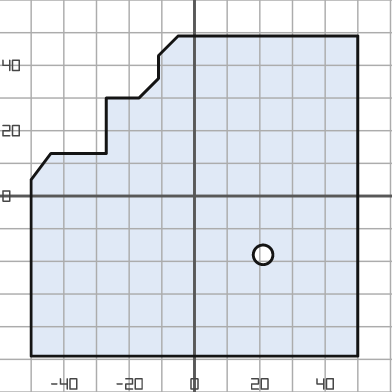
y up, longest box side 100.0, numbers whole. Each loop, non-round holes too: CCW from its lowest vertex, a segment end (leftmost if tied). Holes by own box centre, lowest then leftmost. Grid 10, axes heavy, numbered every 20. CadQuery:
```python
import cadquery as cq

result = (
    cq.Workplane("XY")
    .moveTo(-50.0, -49.0)
    .lineTo(50.0, -49.0)
    .lineTo(50.0, 49.0)
    .lineTo(-5.0, 49.0)
    .lineTo(-11.0, 43.0)
    .lineTo(-11.0, 36.0)
    .lineTo(-17.0, 30.0)
    .lineTo(-27.0, 30.0)
    .lineTo(-27.0, 13.0)
    .lineTo(-44.0, 13.0)
    .lineTo(-50.0, 5.0)
    .close()
    .moveTo(21.0, -18.0)
    .circle(3.0)
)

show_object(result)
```